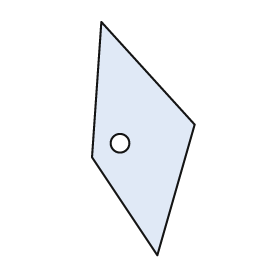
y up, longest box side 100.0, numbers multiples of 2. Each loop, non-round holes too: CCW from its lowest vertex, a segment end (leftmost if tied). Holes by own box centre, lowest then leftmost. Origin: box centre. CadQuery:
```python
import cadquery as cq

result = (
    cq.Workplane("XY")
    .moveTo(6.0, -50.0)
    .lineTo(22.0, 6.0)
    .lineTo(-18.0, 50.0)
    .lineTo(-22.0, -8.0)
    .close()
    .moveTo(-10.0, -2.0)
    .circle(4.0)
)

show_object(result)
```